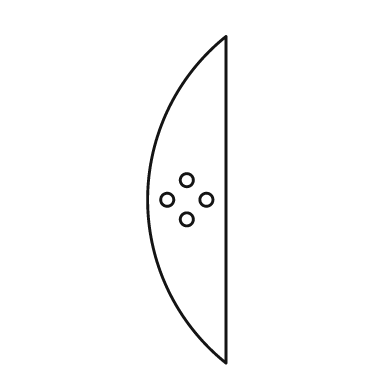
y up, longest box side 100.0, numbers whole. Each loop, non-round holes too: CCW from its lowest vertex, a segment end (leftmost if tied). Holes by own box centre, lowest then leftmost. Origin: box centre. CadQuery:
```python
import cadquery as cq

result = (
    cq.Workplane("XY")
    .moveTo(12.0, -50.0)
    .lineTo(12.0, 50.0)
    .threePointArc((-12.0, 0.0), (12.0, -50.0))
    .close()
    .moveTo(0.0, -6.0)
    .circle(2.0)
    .moveTo(-6.0, 0.0)
    .circle(2.0)
    .moveTo(6.0, 0.0)
    .circle(2.0)
    .moveTo(0.0, 6.0)
    .circle(2.0)
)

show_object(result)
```